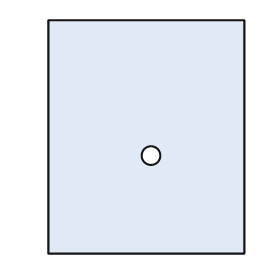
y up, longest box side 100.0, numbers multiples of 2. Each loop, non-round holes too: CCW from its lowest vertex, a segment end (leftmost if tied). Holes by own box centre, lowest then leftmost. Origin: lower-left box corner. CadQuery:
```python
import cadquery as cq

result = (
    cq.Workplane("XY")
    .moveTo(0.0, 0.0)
    .lineTo(84.0, 0.0)
    .lineTo(84.0, 100.0)
    .lineTo(0.0, 100.0)
    .close()
    .moveTo(44.0, 42.0)
    .circle(4.0)
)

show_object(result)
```